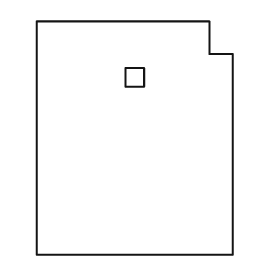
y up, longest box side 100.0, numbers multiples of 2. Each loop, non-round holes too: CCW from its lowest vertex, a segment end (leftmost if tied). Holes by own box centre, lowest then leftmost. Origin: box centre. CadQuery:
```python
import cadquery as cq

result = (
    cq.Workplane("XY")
    .moveTo(-42.0, -50.0)
    .lineTo(42.0, -50.0)
    .lineTo(42.0, 36.0)
    .lineTo(32.0, 36.0)
    .lineTo(32.0, 50.0)
    .lineTo(-42.0, 50.0)
    .close()
    .moveTo(-4.0, 22.0)
    .lineTo(4.0, 22.0)
    .lineTo(4.0, 30.0)
    .lineTo(-4.0, 30.0)
    .close()
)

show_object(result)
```